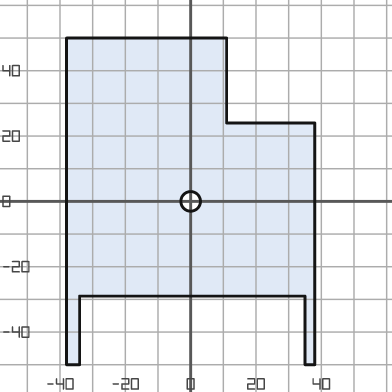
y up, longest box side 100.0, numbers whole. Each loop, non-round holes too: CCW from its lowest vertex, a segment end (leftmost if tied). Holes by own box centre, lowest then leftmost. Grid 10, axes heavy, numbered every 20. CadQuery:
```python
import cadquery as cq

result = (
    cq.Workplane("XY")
    .moveTo(-38.0, -50.0)
    .lineTo(-34.0, -50.0)
    .lineTo(-34.0, -29.0)
    .lineTo(35.0, -29.0)
    .lineTo(35.0, -50.0)
    .lineTo(38.0, -50.0)
    .lineTo(38.0, 24.0)
    .lineTo(11.0, 24.0)
    .lineTo(11.0, 50.0)
    .lineTo(-38.0, 50.0)
    .close()
    .moveTo(0.0, 0.0)
    .circle(3.0)
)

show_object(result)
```